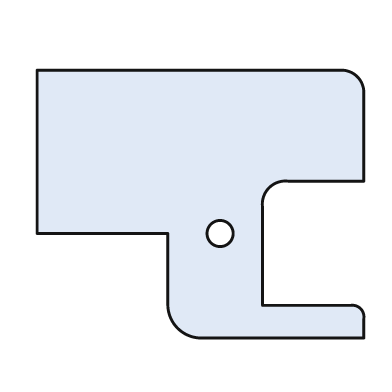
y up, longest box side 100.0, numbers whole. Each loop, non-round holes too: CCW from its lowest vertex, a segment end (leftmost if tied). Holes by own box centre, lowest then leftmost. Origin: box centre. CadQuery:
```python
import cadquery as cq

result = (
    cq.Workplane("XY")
    .moveTo(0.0, -41.0)
    .lineTo(50.0, -41.0)
    .lineTo(50.0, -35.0)
    .threePointArc((49.0, -32.0), (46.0, -31.0))
    .lineTo(19.0, -31.0)
    .lineTo(19.0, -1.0)
    .threePointArc((21.0, 5.0), (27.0, 7.0))
    .lineTo(50.0, 7.0)
    .lineTo(50.0, 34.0)
    .threePointArc((48.0, 39.0), (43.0, 41.0))
    .lineTo(-50.0, 41.0)
    .lineTo(-50.0, -9.0)
    .lineTo(-10.0, -9.0)
    .lineTo(-10.0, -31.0)
    .threePointArc((-7.0, -38.0), (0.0, -41.0))
    .close()
    .moveTo(6.0, -9.0)
    .circle(4.0)
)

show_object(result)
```